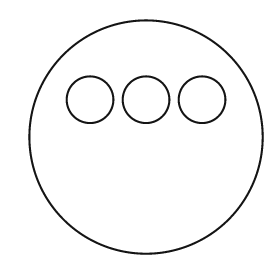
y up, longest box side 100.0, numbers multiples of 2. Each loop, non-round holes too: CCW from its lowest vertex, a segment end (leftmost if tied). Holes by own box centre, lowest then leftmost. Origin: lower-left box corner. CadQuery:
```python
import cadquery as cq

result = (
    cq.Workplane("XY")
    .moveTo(50.0, 50.0)
    .circle(50.0)
    .moveTo(26.0, 66.0)
    .circle(10.0)
    .moveTo(50.0, 66.0)
    .circle(10.0)
    .moveTo(74.0, 66.0)
    .circle(10.0)
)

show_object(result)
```